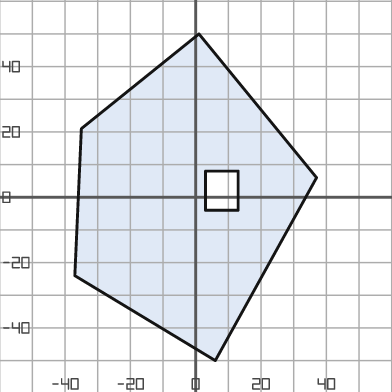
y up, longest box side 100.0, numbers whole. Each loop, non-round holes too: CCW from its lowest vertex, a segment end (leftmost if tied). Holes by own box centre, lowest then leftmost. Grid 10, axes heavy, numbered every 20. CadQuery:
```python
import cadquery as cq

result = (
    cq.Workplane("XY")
    .moveTo(6.0, -50.0)
    .lineTo(37.0, 6.0)
    .lineTo(1.0, 50.0)
    .lineTo(-35.0, 21.0)
    .lineTo(-37.0, -24.0)
    .close()
    .moveTo(3.0, -4.0)
    .lineTo(13.0, -4.0)
    .lineTo(13.0, 8.0)
    .lineTo(3.0, 8.0)
    .close()
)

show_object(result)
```